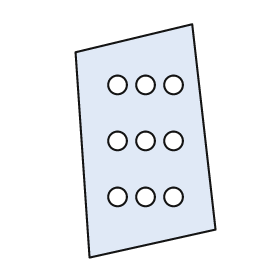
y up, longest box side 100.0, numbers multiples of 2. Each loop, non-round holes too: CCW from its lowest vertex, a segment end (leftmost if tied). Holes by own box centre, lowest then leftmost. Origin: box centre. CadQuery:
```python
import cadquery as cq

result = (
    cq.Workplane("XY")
    .moveTo(-24.0, -50.0)
    .lineTo(30.0, -38.0)
    .lineTo(20.0, 50.0)
    .lineTo(-30.0, 38.0)
    .close()
    .moveTo(-12.0, -24.0)
    .circle(4.0)
    .moveTo(0.0, -24.0)
    .circle(4.0)
    .moveTo(12.0, -24.0)
    .circle(4.0)
    .moveTo(-12.0, 0.0)
    .circle(4.0)
    .moveTo(0.0, 0.0)
    .circle(4.0)
    .moveTo(12.0, 0.0)
    .circle(4.0)
    .moveTo(-12.0, 24.0)
    .circle(4.0)
    .moveTo(0.0, 24.0)
    .circle(4.0)
    .moveTo(12.0, 24.0)
    .circle(4.0)
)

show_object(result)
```